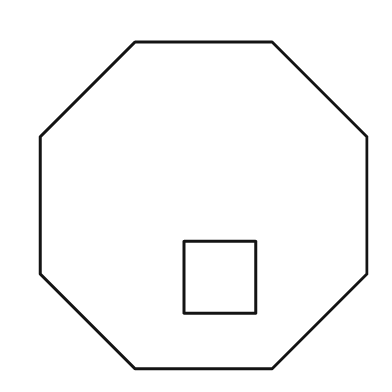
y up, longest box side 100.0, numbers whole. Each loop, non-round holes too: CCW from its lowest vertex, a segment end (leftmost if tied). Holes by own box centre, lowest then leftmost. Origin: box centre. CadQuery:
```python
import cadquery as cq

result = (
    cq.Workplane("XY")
    .moveTo(-21.0, -50.0)
    .lineTo(21.0, -50.0)
    .lineTo(50.0, -21.0)
    .lineTo(50.0, 21.0)
    .lineTo(21.0, 50.0)
    .lineTo(-21.0, 50.0)
    .lineTo(-50.0, 21.0)
    .lineTo(-50.0, -21.0)
    .close()
    .moveTo(-6.0, -33.0)
    .lineTo(16.0, -33.0)
    .lineTo(16.0, -11.0)
    .lineTo(-6.0, -11.0)
    .close()
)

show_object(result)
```